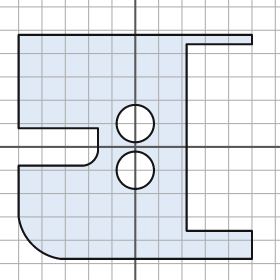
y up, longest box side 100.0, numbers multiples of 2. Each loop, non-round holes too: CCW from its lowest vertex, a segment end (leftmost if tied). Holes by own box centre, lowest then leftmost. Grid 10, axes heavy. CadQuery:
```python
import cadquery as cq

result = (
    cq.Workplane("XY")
    .moveTo(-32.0, -48.0)
    .lineTo(50.0, -48.0)
    .lineTo(50.0, -36.0)
    .lineTo(22.0, -36.0)
    .lineTo(22.0, 44.0)
    .lineTo(50.0, 44.0)
    .lineTo(50.0, 48.0)
    .lineTo(-50.0, 48.0)
    .lineTo(-50.0, 8.0)
    .lineTo(-16.0, 8.0)
    .lineTo(-16.0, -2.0)
    .threePointArc((-18.0, -6.0), (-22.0, -8.0))
    .lineTo(-50.0, -8.0)
    .lineTo(-50.0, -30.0)
    .threePointArc((-44.0, -42.0), (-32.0, -48.0))
    .close()
    .moveTo(0.0, -10.0)
    .circle(8.0)
    .moveTo(0.0, 10.0)
    .circle(8.0)
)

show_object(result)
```